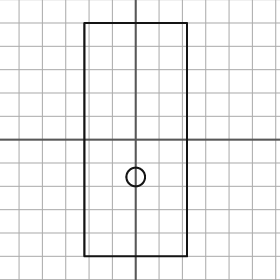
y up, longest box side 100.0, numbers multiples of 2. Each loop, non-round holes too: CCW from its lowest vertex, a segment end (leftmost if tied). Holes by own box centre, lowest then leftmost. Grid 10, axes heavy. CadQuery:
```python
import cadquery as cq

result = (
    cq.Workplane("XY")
    .moveTo(-22.0, -50.0)
    .lineTo(22.0, -50.0)
    .lineTo(22.0, 50.0)
    .lineTo(-22.0, 50.0)
    .close()
    .moveTo(0.0, -16.0)
    .circle(4.0)
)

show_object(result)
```